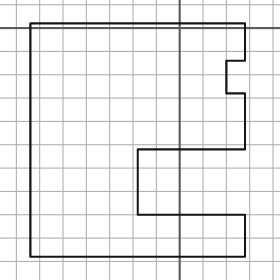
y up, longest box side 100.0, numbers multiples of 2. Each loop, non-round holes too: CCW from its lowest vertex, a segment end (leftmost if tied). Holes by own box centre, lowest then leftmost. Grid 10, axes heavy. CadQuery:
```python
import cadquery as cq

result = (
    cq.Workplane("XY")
    .moveTo(-64.0, -98.0)
    .lineTo(28.0, -98.0)
    .lineTo(28.0, -80.0)
    .lineTo(-18.0, -80.0)
    .lineTo(-18.0, -52.0)
    .lineTo(28.0, -52.0)
    .lineTo(28.0, -28.0)
    .lineTo(20.0, -28.0)
    .lineTo(20.0, -14.0)
    .lineTo(28.0, -14.0)
    .lineTo(28.0, 2.0)
    .lineTo(-64.0, 2.0)
    .close()
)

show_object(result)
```